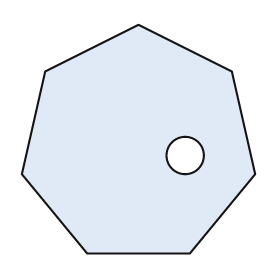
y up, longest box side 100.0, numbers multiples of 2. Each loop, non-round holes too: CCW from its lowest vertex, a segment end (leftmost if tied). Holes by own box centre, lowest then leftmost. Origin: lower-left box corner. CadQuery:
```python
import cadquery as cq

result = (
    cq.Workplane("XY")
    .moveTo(28.0, 0.0)
    .lineTo(72.0, 0.0)
    .lineTo(100.0, 34.0)
    .lineTo(90.0, 78.0)
    .lineTo(50.0, 98.0)
    .lineTo(10.0, 78.0)
    .lineTo(0.0, 34.0)
    .close()
    .moveTo(70.0, 42.0)
    .circle(8.0)
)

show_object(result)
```